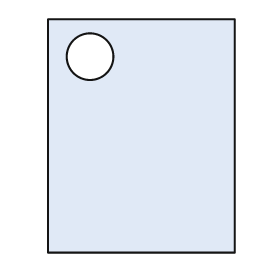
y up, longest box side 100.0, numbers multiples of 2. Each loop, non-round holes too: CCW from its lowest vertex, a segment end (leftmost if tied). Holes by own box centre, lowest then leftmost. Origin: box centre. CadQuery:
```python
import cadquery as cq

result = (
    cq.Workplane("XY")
    .moveTo(-40.0, -50.0)
    .lineTo(40.0, -50.0)
    .lineTo(40.0, 50.0)
    .lineTo(-40.0, 50.0)
    .close()
    .moveTo(-22.0, 34.0)
    .circle(10.0)
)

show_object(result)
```